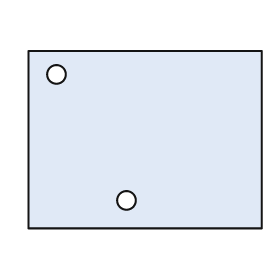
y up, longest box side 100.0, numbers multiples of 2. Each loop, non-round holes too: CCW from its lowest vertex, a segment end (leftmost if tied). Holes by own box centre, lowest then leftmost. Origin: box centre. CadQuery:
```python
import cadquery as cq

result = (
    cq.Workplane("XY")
    .moveTo(-50.0, -38.0)
    .lineTo(50.0, -38.0)
    .lineTo(50.0, 38.0)
    .lineTo(-50.0, 38.0)
    .close()
    .moveTo(-8.0, -26.0)
    .circle(4.0)
    .moveTo(-38.0, 28.0)
    .circle(4.0)
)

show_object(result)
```